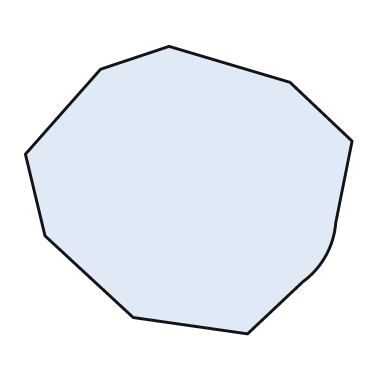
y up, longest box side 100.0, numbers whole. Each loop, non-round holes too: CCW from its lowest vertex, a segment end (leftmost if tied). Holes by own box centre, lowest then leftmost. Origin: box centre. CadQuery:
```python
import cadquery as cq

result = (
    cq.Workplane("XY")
    .moveTo(18.0, -44.0)
    .lineTo(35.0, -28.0)
    .threePointArc((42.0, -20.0), (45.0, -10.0))
    .lineTo(50.0, 15.0)
    .lineTo(31.0, 33.0)
    .lineTo(-6.0, 44.0)
    .lineTo(-27.0, 37.0)
    .lineTo(-50.0, 11.0)
    .lineTo(-44.0, -14.0)
    .lineTo(-17.0, -39.0)
    .close()
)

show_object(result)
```